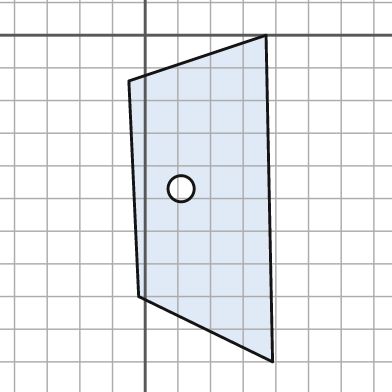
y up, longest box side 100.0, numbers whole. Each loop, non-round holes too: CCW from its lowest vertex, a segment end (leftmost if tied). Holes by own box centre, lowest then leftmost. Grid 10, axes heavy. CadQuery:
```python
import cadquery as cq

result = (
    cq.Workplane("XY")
    .moveTo(39.0, -100.0)
    .lineTo(37.0, 0.0)
    .lineTo(-5.0, -14.0)
    .lineTo(-2.0, -80.0)
    .close()
    .moveTo(11.0, -47.0)
    .circle(4.0)
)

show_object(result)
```